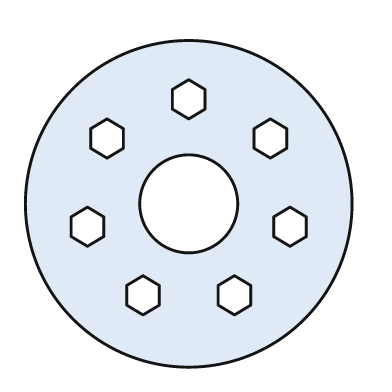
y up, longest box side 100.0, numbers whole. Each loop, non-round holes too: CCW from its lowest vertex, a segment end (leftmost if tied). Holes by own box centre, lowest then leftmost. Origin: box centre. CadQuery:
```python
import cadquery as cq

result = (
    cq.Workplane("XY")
    .moveTo(0.0, 0.0)
    .circle(50.0)
    .moveTo(-14.0, -34.0)
    .lineTo(-9.0, -31.0)
    .lineTo(-9.0, -25.0)
    .lineTo(-14.0, -22.0)
    .lineTo(-19.0, -25.0)
    .lineTo(-19.0, -31.0)
    .close()
    .moveTo(14.0, -34.0)
    .lineTo(19.0, -31.0)
    .lineTo(19.0, -25.0)
    .lineTo(14.0, -22.0)
    .lineTo(9.0, -25.0)
    .lineTo(9.0, -31.0)
    .close()
    .moveTo(-31.0, -13.0)
    .lineTo(-26.0, -10.0)
    .lineTo(-26.0, -4.0)
    .lineTo(-31.0, -1.0)
    .lineTo(-36.0, -4.0)
    .lineTo(-36.0, -10.0)
    .close()
    .moveTo(31.0, -13.0)
    .lineTo(36.0, -10.0)
    .lineTo(36.0, -4.0)
    .lineTo(31.0, -1.0)
    .lineTo(26.0, -4.0)
    .lineTo(26.0, -10.0)
    .close()
    .moveTo(0.0, 0.0)
    .circle(15.0)
    .moveTo(-25.0, 14.0)
    .lineTo(-20.0, 17.0)
    .lineTo(-20.0, 23.0)
    .lineTo(-25.0, 26.0)
    .lineTo(-30.0, 23.0)
    .lineTo(-30.0, 17.0)
    .close()
    .moveTo(25.0, 14.0)
    .lineTo(30.0, 17.0)
    .lineTo(30.0, 23.0)
    .lineTo(25.0, 26.0)
    .lineTo(20.0, 23.0)
    .lineTo(20.0, 17.0)
    .close()
    .moveTo(0.0, 26.0)
    .lineTo(5.0, 29.0)
    .lineTo(5.0, 35.0)
    .lineTo(0.0, 38.0)
    .lineTo(-5.0, 35.0)
    .lineTo(-5.0, 29.0)
    .close()
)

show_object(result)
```